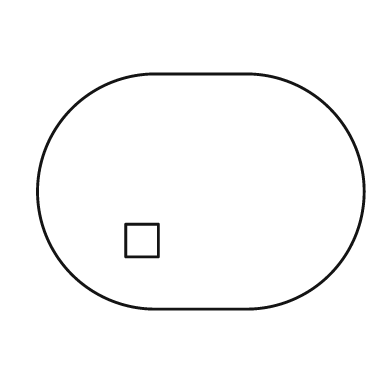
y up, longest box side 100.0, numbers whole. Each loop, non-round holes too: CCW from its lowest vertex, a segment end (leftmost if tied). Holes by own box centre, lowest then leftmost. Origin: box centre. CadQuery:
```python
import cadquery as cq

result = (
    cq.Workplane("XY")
    .moveTo(-14.0, -36.0)
    .lineTo(14.0, -36.0)
    .threePointArc((50.0, 0.0), (14.0, 36.0))
    .lineTo(-14.0, 36.0)
    .threePointArc((-50.0, 0.0), (-14.0, -36.0))
    .close()
    .moveTo(-23.0, -20.0)
    .lineTo(-13.0, -20.0)
    .lineTo(-13.0, -10.0)
    .lineTo(-23.0, -10.0)
    .close()
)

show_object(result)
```